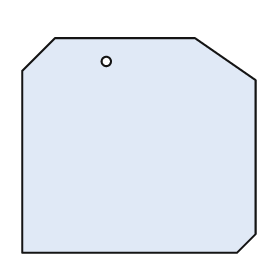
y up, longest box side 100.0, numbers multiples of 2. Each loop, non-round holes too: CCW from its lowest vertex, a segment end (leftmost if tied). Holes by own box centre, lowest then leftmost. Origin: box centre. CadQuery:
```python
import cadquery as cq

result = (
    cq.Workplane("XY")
    .moveTo(-50.0, -46.0)
    .lineTo(42.0, -46.0)
    .lineTo(50.0, -38.0)
    .lineTo(50.0, 28.0)
    .lineTo(24.0, 46.0)
    .lineTo(-36.0, 46.0)
    .lineTo(-50.0, 32.0)
    .close()
    .moveTo(-14.0, 36.0)
    .circle(2.0)
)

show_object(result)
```